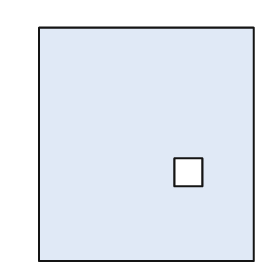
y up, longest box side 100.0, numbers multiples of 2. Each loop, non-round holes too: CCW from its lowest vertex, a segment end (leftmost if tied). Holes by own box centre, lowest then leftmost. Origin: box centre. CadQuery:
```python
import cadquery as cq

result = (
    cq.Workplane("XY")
    .moveTo(-46.0, -50.0)
    .lineTo(46.0, -50.0)
    .lineTo(46.0, 50.0)
    .lineTo(-46.0, 50.0)
    .close()
    .moveTo(12.0, -18.0)
    .lineTo(24.0, -18.0)
    .lineTo(24.0, -6.0)
    .lineTo(12.0, -6.0)
    .close()
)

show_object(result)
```